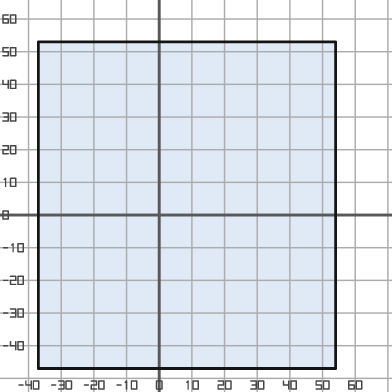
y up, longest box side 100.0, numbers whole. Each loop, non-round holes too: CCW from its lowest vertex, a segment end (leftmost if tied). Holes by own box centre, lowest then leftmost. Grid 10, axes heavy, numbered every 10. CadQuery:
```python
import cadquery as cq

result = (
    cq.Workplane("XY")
    .moveTo(-37.0, -47.0)
    .lineTo(54.0, -47.0)
    .lineTo(54.0, 53.0)
    .lineTo(-37.0, 53.0)
    .close()
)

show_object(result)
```